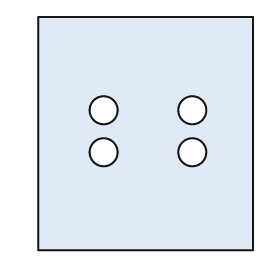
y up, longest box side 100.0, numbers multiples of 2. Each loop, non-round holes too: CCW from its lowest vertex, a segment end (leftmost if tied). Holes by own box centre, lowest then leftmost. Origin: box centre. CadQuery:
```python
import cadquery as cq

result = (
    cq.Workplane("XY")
    .moveTo(-46.0, -50.0)
    .lineTo(46.0, -50.0)
    .lineTo(46.0, 50.0)
    .lineTo(-46.0, 50.0)
    .close()
    .moveTo(-18.0, -8.0)
    .circle(6.0)
    .moveTo(20.0, -8.0)
    .circle(6.0)
    .moveTo(-18.0, 10.0)
    .circle(6.0)
    .moveTo(20.0, 10.0)
    .circle(6.0)
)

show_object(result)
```